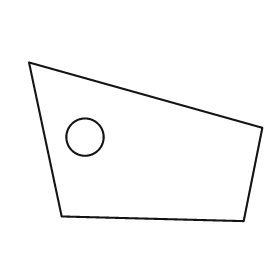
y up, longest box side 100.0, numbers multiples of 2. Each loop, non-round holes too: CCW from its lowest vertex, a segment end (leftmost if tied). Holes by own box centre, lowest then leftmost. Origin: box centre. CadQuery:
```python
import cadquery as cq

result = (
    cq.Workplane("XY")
    .moveTo(42.0, -34.0)
    .lineTo(50.0, 6.0)
    .lineTo(-50.0, 34.0)
    .lineTo(-36.0, -32.0)
    .close()
    .moveTo(-26.0, 2.0)
    .circle(8.0)
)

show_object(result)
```